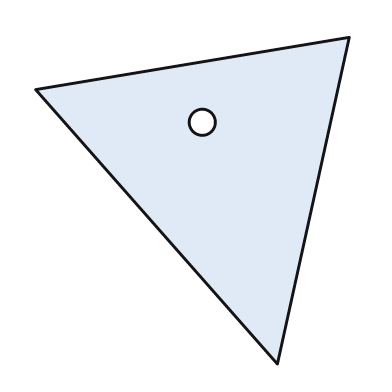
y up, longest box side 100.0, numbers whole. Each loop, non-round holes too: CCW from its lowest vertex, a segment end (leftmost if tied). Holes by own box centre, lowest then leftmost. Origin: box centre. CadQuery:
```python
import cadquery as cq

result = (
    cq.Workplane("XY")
    .moveTo(26.0, -50.0)
    .lineTo(48.0, 50.0)
    .lineTo(-48.0, 34.0)
    .close()
    .moveTo(3.0, 24.0)
    .circle(4.0)
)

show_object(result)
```